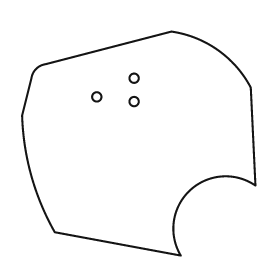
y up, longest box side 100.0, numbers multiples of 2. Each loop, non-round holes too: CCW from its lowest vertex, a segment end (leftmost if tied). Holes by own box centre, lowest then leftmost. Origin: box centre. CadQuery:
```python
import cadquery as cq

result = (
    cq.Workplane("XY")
    .moveTo(18.0, -48.0)
    .threePointArc((22.0, -20.0), (50.0, -18.0))
    .lineTo(48.0, 24.0)
    .threePointArc((34.0, 40.0), (14.0, 48.0))
    .lineTo(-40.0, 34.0)
    .threePointArc((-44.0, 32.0), (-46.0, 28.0))
    .lineTo(-50.0, 12.0)
    .threePointArc((-46.0, -14.0), (-36.0, -38.0))
    .close()
    .moveTo(-2.0, 18.0)
    .circle(2.0)
    .moveTo(-18.0, 20.0)
    .circle(2.0)
    .moveTo(-2.0, 28.0)
    .circle(2.0)
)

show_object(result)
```